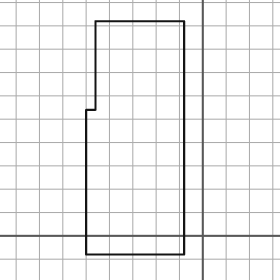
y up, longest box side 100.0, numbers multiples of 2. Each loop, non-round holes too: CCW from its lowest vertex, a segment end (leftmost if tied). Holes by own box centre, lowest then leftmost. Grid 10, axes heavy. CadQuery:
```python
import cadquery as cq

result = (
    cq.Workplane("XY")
    .moveTo(-50.0, -8.0)
    .lineTo(-8.0, -8.0)
    .lineTo(-8.0, 92.0)
    .lineTo(-46.0, 92.0)
    .lineTo(-46.0, 54.0)
    .lineTo(-50.0, 54.0)
    .close()
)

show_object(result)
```